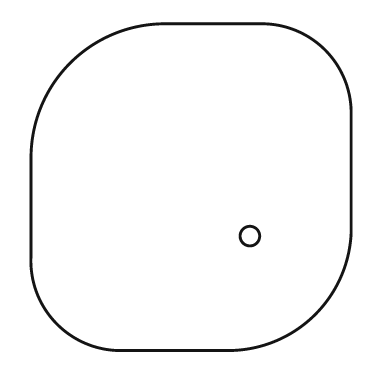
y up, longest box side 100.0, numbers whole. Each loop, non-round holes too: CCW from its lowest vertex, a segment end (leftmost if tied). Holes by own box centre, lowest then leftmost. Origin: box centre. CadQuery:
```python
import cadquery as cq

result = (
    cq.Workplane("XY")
    .moveTo(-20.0, -50.0)
    .lineTo(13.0, -50.0)
    .threePointArc((38.0, -39.0), (49.0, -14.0))
    .lineTo(49.0, 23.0)
    .threePointArc((41.0, 42.0), (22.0, 50.0))
    .lineTo(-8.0, 50.0)
    .threePointArc((-37.0, 38.0), (-49.0, 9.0))
    .lineTo(-49.0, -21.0)
    .threePointArc((-41.0, -42.0), (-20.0, -50.0))
    .close()
    .moveTo(18.0, -15.0)
    .circle(3.0)
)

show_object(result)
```